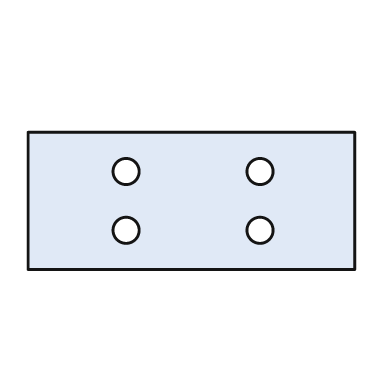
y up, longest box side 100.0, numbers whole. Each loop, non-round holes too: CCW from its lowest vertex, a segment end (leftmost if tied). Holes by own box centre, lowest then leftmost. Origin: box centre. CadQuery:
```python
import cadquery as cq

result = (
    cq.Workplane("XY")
    .moveTo(-50.0, -21.0)
    .lineTo(50.0, -21.0)
    .lineTo(50.0, 21.0)
    .lineTo(-50.0, 21.0)
    .close()
    .moveTo(-20.0, -9.0)
    .circle(4.0)
    .moveTo(21.0, -9.0)
    .circle(4.0)
    .moveTo(-20.0, 9.0)
    .circle(4.0)
    .moveTo(21.0, 9.0)
    .circle(4.0)
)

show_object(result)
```